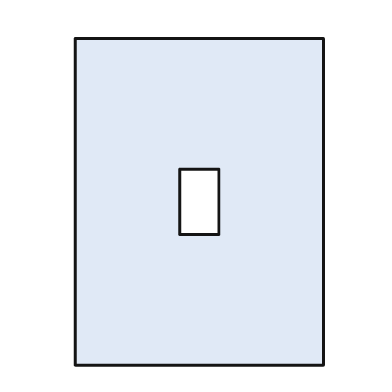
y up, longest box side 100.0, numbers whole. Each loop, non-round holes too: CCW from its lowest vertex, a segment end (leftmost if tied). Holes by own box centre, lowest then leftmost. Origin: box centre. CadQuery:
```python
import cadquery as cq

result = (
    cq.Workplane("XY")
    .moveTo(-38.0, -50.0)
    .lineTo(38.0, -50.0)
    .lineTo(38.0, 50.0)
    .lineTo(-38.0, 50.0)
    .close()
    .moveTo(-6.0, -10.0)
    .lineTo(6.0, -10.0)
    .lineTo(6.0, 10.0)
    .lineTo(-6.0, 10.0)
    .close()
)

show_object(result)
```